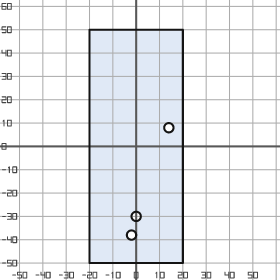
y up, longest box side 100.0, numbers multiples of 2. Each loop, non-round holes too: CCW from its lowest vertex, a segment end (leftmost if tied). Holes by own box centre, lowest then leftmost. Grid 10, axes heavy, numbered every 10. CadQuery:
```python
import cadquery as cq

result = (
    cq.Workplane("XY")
    .moveTo(-20.0, -50.0)
    .lineTo(20.0, -50.0)
    .lineTo(20.0, 50.0)
    .lineTo(-20.0, 50.0)
    .close()
    .moveTo(-2.0, -38.0)
    .circle(2.0)
    .moveTo(0.0, -30.0)
    .circle(2.0)
    .moveTo(14.0, 8.0)
    .circle(2.0)
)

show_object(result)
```